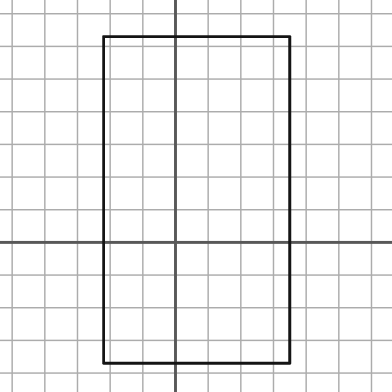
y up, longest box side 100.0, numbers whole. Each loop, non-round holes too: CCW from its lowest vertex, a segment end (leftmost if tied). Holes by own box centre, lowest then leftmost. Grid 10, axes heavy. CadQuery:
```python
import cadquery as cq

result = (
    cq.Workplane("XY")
    .moveTo(-22.0, -37.0)
    .lineTo(35.0, -37.0)
    .lineTo(35.0, 63.0)
    .lineTo(-22.0, 63.0)
    .close()
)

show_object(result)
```